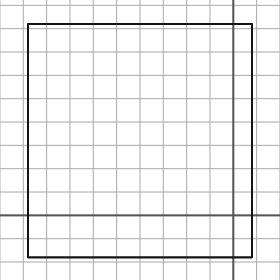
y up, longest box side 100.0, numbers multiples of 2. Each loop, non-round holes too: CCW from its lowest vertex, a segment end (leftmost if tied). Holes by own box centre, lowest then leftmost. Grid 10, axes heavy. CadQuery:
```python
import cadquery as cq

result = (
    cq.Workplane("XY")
    .moveTo(-88.0, -18.0)
    .lineTo(8.0, -18.0)
    .lineTo(8.0, 82.0)
    .lineTo(-88.0, 82.0)
    .close()
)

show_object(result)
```